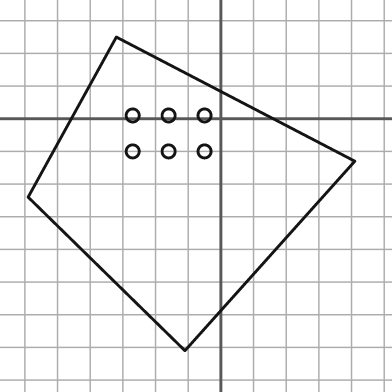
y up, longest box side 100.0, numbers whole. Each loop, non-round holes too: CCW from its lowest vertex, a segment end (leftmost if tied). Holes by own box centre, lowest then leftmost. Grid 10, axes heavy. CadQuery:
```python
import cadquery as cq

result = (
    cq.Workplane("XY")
    .moveTo(-11.0, -71.0)
    .lineTo(41.0, -13.0)
    .lineTo(-32.0, 25.0)
    .lineTo(-59.0, -24.0)
    .close()
    .moveTo(-27.0, -10.0)
    .circle(2.0)
    .moveTo(-16.0, -10.0)
    .circle(2.0)
    .moveTo(-5.0, -10.0)
    .circle(2.0)
    .moveTo(-27.0, 1.0)
    .circle(2.0)
    .moveTo(-16.0, 1.0)
    .circle(2.0)
    .moveTo(-5.0, 1.0)
    .circle(2.0)
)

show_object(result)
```